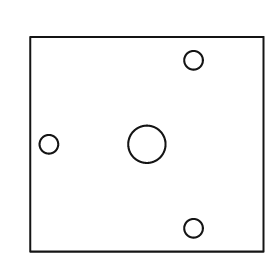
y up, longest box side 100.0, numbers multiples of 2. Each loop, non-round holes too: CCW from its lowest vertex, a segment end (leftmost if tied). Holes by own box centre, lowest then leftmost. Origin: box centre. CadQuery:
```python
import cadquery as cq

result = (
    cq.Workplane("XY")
    .moveTo(-50.0, -46.0)
    .lineTo(50.0, -46.0)
    .lineTo(50.0, 46.0)
    .lineTo(-50.0, 46.0)
    .close()
    .moveTo(20.0, -36.0)
    .circle(4.0)
    .moveTo(-42.0, 0.0)
    .circle(4.0)
    .moveTo(0.0, 0.0)
    .circle(8.0)
    .moveTo(20.0, 36.0)
    .circle(4.0)
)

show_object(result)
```